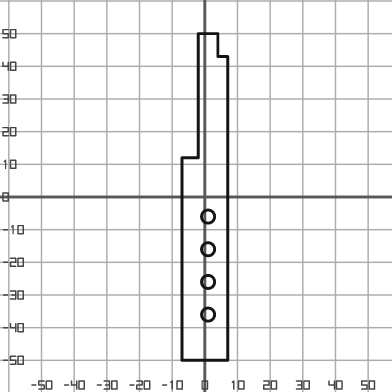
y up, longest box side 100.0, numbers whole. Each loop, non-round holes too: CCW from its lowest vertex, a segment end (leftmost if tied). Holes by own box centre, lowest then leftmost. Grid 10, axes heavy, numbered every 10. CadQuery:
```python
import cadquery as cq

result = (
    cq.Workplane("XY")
    .moveTo(-7.0, -50.0)
    .lineTo(7.0, -50.0)
    .lineTo(7.0, 43.0)
    .lineTo(4.0, 43.0)
    .lineTo(4.0, 50.0)
    .lineTo(-2.0, 50.0)
    .lineTo(-2.0, 12.0)
    .lineTo(-7.0, 12.0)
    .close()
    .moveTo(1.0, -36.0)
    .circle(2.0)
    .moveTo(1.0, -26.0)
    .circle(2.0)
    .moveTo(1.0, -16.0)
    .circle(2.0)
    .moveTo(1.0, -6.0)
    .circle(2.0)
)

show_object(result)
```